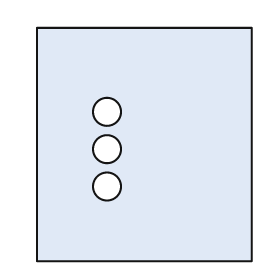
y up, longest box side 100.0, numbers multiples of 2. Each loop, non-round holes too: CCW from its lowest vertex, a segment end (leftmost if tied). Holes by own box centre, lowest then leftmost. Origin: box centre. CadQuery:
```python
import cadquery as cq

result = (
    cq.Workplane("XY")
    .moveTo(-46.0, -50.0)
    .lineTo(46.0, -50.0)
    .lineTo(46.0, 50.0)
    .lineTo(-46.0, 50.0)
    .close()
    .moveTo(-16.0, -18.0)
    .circle(6.0)
    .moveTo(-16.0, -2.0)
    .circle(6.0)
    .moveTo(-16.0, 14.0)
    .circle(6.0)
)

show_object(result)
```